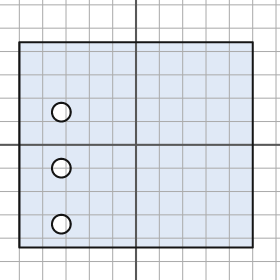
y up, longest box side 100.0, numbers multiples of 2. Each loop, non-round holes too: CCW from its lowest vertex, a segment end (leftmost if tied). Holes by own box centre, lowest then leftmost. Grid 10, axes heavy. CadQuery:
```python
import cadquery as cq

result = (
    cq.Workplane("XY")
    .moveTo(-50.0, -44.0)
    .lineTo(50.0, -44.0)
    .lineTo(50.0, 44.0)
    .lineTo(-50.0, 44.0)
    .close()
    .moveTo(-32.0, -34.0)
    .circle(4.0)
    .moveTo(-32.0, -10.0)
    .circle(4.0)
    .moveTo(-32.0, 14.0)
    .circle(4.0)
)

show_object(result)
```